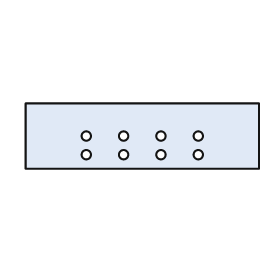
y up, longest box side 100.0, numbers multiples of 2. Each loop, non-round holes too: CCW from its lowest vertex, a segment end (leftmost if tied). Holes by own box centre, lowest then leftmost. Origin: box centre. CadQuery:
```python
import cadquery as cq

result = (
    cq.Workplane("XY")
    .moveTo(-50.0, -14.0)
    .lineTo(50.0, -14.0)
    .lineTo(50.0, 14.0)
    .lineTo(-50.0, 14.0)
    .close()
    .moveTo(-24.0, -8.0)
    .circle(2.0)
    .moveTo(-8.0, -8.0)
    .circle(2.0)
    .moveTo(8.0, -8.0)
    .circle(2.0)
    .moveTo(24.0, -8.0)
    .circle(2.0)
    .moveTo(-24.0, 0.0)
    .circle(2.0)
    .moveTo(-8.0, 0.0)
    .circle(2.0)
    .moveTo(8.0, 0.0)
    .circle(2.0)
    .moveTo(24.0, 0.0)
    .circle(2.0)
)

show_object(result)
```